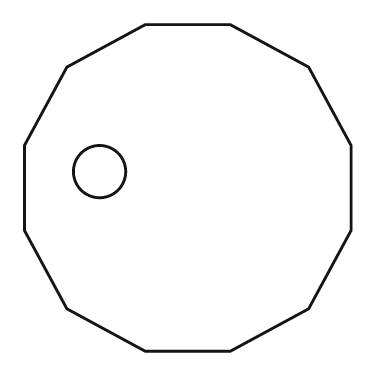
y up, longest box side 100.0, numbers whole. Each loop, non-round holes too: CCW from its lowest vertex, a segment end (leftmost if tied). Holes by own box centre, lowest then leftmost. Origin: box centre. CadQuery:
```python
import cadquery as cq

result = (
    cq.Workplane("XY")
    .moveTo(-13.0, -50.0)
    .lineTo(13.0, -50.0)
    .lineTo(37.0, -37.0)
    .lineTo(50.0, -13.0)
    .lineTo(50.0, 13.0)
    .lineTo(37.0, 37.0)
    .lineTo(13.0, 50.0)
    .lineTo(-13.0, 50.0)
    .lineTo(-37.0, 37.0)
    .lineTo(-50.0, 13.0)
    .lineTo(-50.0, -13.0)
    .lineTo(-37.0, -37.0)
    .close()
    .moveTo(-27.0, 5.0)
    .circle(8.0)
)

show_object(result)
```